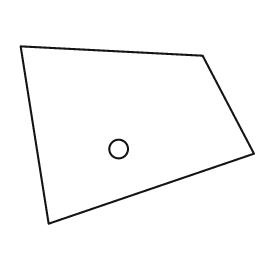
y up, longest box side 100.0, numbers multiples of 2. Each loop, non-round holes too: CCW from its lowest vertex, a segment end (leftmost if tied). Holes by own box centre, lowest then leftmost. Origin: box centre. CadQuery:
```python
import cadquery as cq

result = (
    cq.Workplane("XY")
    .moveTo(-38.0, -38.0)
    .lineTo(50.0, -8.0)
    .lineTo(28.0, 34.0)
    .lineTo(-50.0, 38.0)
    .close()
    .moveTo(-8.0, -6.0)
    .circle(4.0)
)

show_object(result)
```